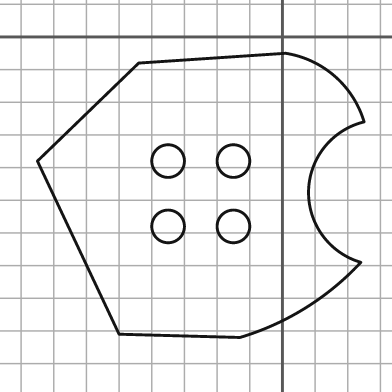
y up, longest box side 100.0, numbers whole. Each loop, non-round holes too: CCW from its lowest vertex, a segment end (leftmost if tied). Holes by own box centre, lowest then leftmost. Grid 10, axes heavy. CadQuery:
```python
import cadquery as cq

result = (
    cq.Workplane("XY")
    .moveTo(-13.0, -92.0)
    .threePointArc((7.0, -83.0), (24.0, -69.0))
    .threePointArc((8.0, -47.0), (25.0, -26.0))
    .threePointArc((16.0, -12.0), (1.0, -5.0))
    .lineTo(-44.0, -8.0)
    .lineTo(-75.0, -38.0)
    .lineTo(-50.0, -91.0)
    .close()
    .moveTo(-35.0, -58.0)
    .circle(5.0)
    .moveTo(-15.0, -58.0)
    .circle(5.0)
    .moveTo(-35.0, -38.0)
    .circle(5.0)
    .moveTo(-15.0, -38.0)
    .circle(5.0)
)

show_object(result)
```